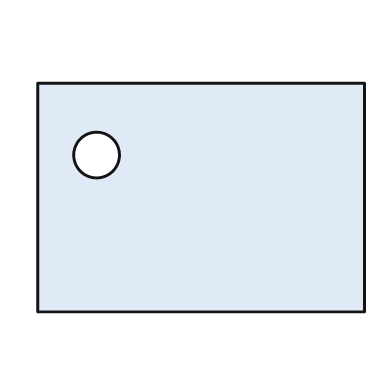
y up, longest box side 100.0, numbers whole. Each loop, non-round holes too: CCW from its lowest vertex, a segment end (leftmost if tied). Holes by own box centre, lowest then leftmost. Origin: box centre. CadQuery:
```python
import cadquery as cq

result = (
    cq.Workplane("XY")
    .moveTo(-50.0, -35.0)
    .lineTo(50.0, -35.0)
    .lineTo(50.0, 35.0)
    .lineTo(-50.0, 35.0)
    .close()
    .moveTo(-32.0, 13.0)
    .circle(7.0)
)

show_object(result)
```